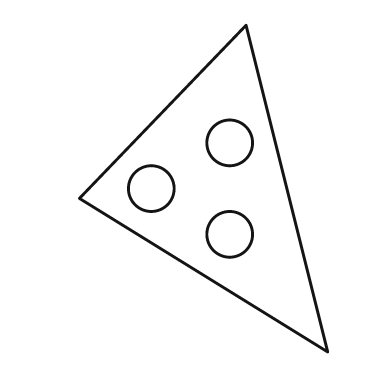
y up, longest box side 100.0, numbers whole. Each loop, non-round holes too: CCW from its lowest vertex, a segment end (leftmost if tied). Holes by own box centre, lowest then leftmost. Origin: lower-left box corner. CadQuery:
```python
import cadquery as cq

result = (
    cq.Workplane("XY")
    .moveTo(76.0, 0.0)
    .lineTo(51.0, 100.0)
    .lineTo(0.0, 47.0)
    .close()
    .moveTo(46.0, 36.0)
    .circle(7.0)
    .moveTo(22.0, 50.0)
    .circle(7.0)
    .moveTo(46.0, 64.0)
    .circle(7.0)
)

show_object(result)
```